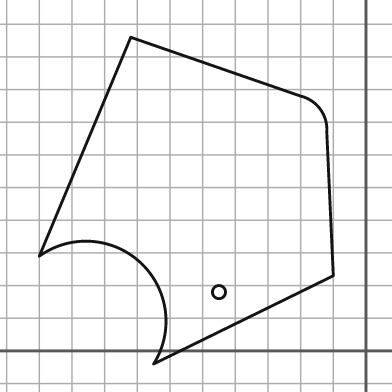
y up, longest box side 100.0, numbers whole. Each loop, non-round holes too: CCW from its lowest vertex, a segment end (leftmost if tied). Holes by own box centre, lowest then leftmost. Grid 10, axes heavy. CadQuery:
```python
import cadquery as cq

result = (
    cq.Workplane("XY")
    .moveTo(-65.0, -4.0)
    .lineTo(-10.0, 23.0)
    .lineTo(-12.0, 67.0)
    .threePointArc((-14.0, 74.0), (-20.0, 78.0))
    .lineTo(-72.0, 96.0)
    .lineTo(-100.0, 29.0)
    .threePointArc((-69.0, 27.0), (-65.0, -4.0))
    .close()
    .moveTo(-45.0, 18.0)
    .circle(2.0)
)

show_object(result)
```